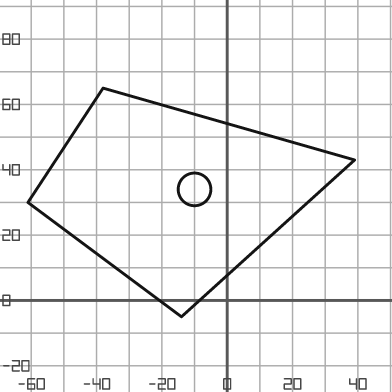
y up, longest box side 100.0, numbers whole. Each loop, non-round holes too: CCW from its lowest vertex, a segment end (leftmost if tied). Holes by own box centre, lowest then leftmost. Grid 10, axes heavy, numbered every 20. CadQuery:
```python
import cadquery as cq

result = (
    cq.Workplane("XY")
    .moveTo(-14.0, -5.0)
    .lineTo(39.0, 43.0)
    .lineTo(-38.0, 65.0)
    .lineTo(-61.0, 30.0)
    .close()
    .moveTo(-10.0, 34.0)
    .circle(5.0)
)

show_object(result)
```